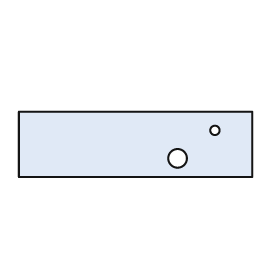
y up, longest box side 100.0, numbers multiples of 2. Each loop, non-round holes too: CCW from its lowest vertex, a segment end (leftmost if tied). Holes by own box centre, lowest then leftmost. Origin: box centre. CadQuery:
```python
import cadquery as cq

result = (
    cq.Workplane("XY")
    .moveTo(-50.0, -14.0)
    .lineTo(50.0, -14.0)
    .lineTo(50.0, 14.0)
    .lineTo(-50.0, 14.0)
    .close()
    .moveTo(18.0, -6.0)
    .circle(4.0)
    .moveTo(34.0, 6.0)
    .circle(2.0)
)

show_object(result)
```